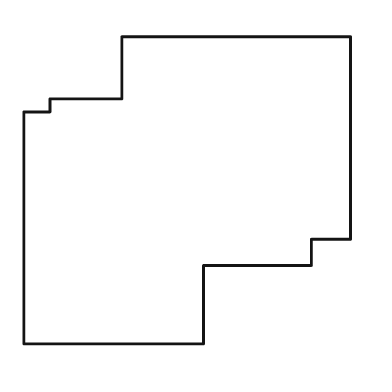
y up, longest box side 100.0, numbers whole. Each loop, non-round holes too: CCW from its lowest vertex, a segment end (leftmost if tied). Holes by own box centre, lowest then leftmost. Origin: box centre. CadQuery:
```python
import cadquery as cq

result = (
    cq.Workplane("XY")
    .moveTo(-50.0, -47.0)
    .lineTo(5.0, -47.0)
    .lineTo(5.0, -23.0)
    .lineTo(38.0, -23.0)
    .lineTo(38.0, -15.0)
    .lineTo(50.0, -15.0)
    .lineTo(50.0, 47.0)
    .lineTo(-20.0, 47.0)
    .lineTo(-20.0, 28.0)
    .lineTo(-42.0, 28.0)
    .lineTo(-42.0, 24.0)
    .lineTo(-50.0, 24.0)
    .close()
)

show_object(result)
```